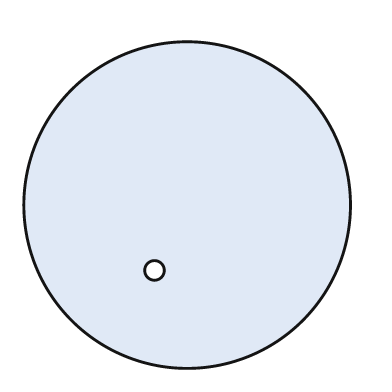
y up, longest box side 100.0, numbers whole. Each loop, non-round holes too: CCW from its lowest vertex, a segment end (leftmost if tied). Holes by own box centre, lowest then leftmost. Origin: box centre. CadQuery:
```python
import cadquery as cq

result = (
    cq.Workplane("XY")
    .moveTo(0.0, 0.0)
    .circle(50.0)
    .moveTo(-10.0, -20.0)
    .circle(3.0)
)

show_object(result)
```